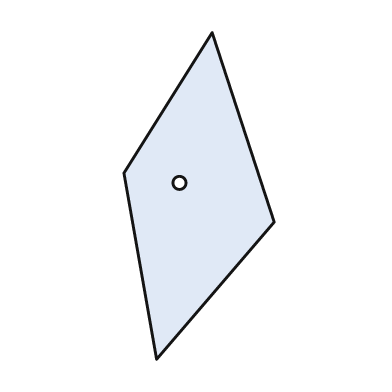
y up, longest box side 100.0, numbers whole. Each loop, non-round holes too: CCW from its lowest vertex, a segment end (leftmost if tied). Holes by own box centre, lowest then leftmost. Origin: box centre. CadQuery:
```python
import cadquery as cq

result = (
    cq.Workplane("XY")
    .moveTo(-13.0, -50.0)
    .lineTo(23.0, -8.0)
    .lineTo(4.0, 50.0)
    .lineTo(-23.0, 7.0)
    .close()
    .moveTo(-6.0, 4.0)
    .circle(2.0)
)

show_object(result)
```